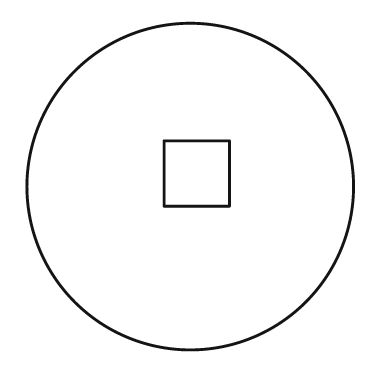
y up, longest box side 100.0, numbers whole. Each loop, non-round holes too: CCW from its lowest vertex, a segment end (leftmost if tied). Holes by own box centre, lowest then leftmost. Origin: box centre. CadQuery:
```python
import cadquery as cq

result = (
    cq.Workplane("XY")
    .moveTo(0.0, 0.0)
    .circle(50.0)
    .moveTo(-8.0, -6.0)
    .lineTo(12.0, -6.0)
    .lineTo(12.0, 14.0)
    .lineTo(-8.0, 14.0)
    .close()
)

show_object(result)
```